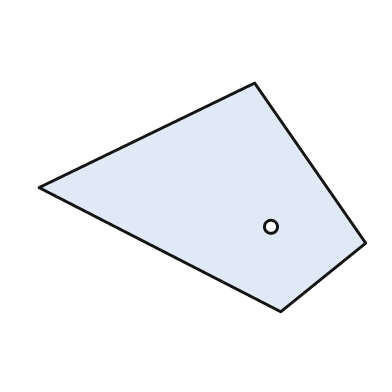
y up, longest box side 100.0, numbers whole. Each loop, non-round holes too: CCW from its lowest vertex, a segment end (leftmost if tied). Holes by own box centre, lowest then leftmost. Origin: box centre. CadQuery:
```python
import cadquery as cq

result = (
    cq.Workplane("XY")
    .moveTo(24.0, -35.0)
    .lineTo(50.0, -14.0)
    .lineTo(16.0, 35.0)
    .lineTo(-50.0, 3.0)
    .close()
    .moveTo(21.0, -9.0)
    .circle(2.0)
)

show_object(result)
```